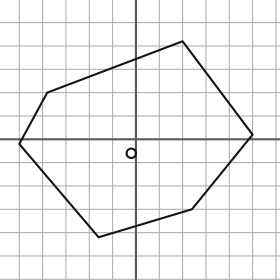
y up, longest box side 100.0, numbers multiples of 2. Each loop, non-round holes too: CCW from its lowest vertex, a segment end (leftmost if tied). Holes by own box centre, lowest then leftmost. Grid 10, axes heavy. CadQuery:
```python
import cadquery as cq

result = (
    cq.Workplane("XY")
    .moveTo(-16.0, -42.0)
    .lineTo(24.0, -30.0)
    .lineTo(50.0, 2.0)
    .lineTo(20.0, 42.0)
    .lineTo(-38.0, 20.0)
    .lineTo(-50.0, -2.0)
    .close()
    .moveTo(-2.0, -6.0)
    .circle(2.0)
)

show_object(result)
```